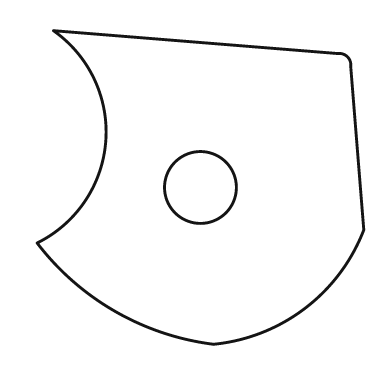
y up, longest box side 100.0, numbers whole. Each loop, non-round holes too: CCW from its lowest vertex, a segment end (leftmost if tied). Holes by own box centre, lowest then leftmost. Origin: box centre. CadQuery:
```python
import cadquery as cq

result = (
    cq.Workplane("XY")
    .moveTo(4.0, -48.0)
    .threePointArc((32.0, -37.0), (50.0, -13.0))
    .lineTo(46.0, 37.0)
    .threePointArc((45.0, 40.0), (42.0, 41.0))
    .lineTo(-45.0, 48.0)
    .threePointArc((-29.0, 14.0), (-50.0, -17.0))
    .threePointArc((-26.0, -38.0), (4.0, -48.0))
    .close()
    .moveTo(0.0, 0.0)
    .circle(11.0)
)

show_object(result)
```